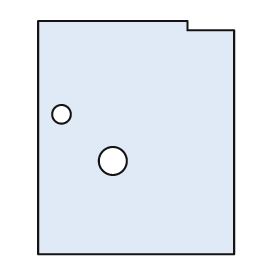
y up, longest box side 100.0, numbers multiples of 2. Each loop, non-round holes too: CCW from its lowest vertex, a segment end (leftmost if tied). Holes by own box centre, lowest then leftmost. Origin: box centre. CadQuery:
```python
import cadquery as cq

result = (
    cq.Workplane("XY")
    .moveTo(-42.0, -50.0)
    .lineTo(42.0, -50.0)
    .lineTo(42.0, 46.0)
    .lineTo(22.0, 46.0)
    .lineTo(22.0, 50.0)
    .lineTo(-42.0, 50.0)
    .close()
    .moveTo(-10.0, -10.0)
    .circle(6.0)
    .moveTo(-32.0, 10.0)
    .circle(4.0)
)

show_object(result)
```